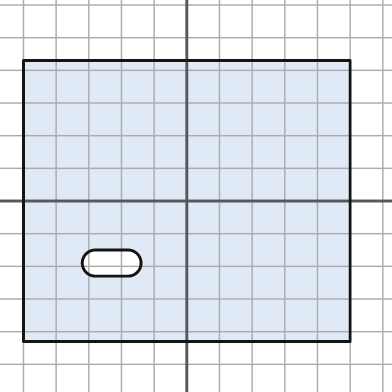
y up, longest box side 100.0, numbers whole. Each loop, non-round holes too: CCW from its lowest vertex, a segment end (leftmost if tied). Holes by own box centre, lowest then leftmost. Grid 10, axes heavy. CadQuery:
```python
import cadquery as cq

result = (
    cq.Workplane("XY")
    .moveTo(-50.0, -43.0)
    .lineTo(50.0, -43.0)
    .lineTo(50.0, 43.0)
    .lineTo(-50.0, 43.0)
    .close()
    .moveTo(-28.0, -23.0)
    .lineTo(-18.0, -23.0)
    .threePointArc((-14.0, -19.0), (-18.0, -15.0))
    .lineTo(-28.0, -15.0)
    .threePointArc((-32.0, -19.0), (-28.0, -23.0))
    .close()
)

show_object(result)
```